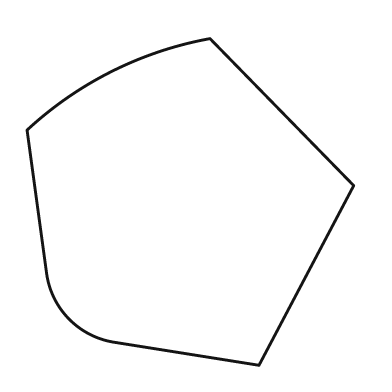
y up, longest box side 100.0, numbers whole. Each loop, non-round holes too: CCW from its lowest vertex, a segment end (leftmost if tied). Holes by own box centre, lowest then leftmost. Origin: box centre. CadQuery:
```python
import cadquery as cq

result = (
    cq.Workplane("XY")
    .moveTo(21.0, -50.0)
    .lineTo(50.0, 5.0)
    .lineTo(6.0, 50.0)
    .threePointArc((-24.0, 40.0), (-50.0, 22.0))
    .lineTo(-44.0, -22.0)
    .threePointArc((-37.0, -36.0), (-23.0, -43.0))
    .close()
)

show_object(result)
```